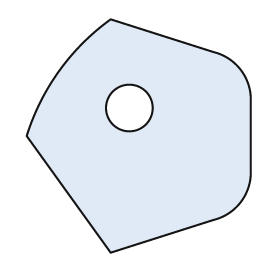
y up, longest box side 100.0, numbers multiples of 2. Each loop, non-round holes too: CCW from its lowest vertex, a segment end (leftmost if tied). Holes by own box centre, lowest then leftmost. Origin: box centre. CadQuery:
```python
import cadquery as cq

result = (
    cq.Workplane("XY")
    .moveTo(-12.0, -50.0)
    .lineTo(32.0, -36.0)
    .threePointArc((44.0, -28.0), (48.0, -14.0))
    .lineTo(48.0, 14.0)
    .threePointArc((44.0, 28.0), (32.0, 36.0))
    .lineTo(-12.0, 50.0)
    .threePointArc((-34.0, 28.0), (-48.0, 0.0))
    .close()
    .moveTo(-4.0, 12.0)
    .circle(10.0)
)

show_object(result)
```